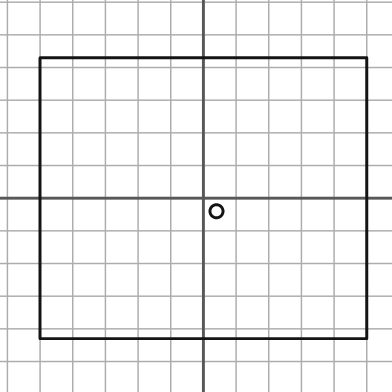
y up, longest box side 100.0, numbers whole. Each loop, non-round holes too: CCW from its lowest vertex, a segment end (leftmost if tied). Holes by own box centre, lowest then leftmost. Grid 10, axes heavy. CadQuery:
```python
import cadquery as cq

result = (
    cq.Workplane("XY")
    .moveTo(-50.0, -43.0)
    .lineTo(50.0, -43.0)
    .lineTo(50.0, 43.0)
    .lineTo(-50.0, 43.0)
    .close()
    .moveTo(4.0, -4.0)
    .circle(2.0)
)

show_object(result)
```